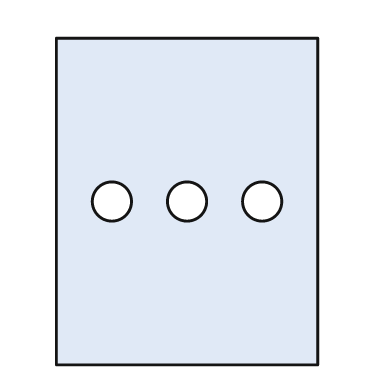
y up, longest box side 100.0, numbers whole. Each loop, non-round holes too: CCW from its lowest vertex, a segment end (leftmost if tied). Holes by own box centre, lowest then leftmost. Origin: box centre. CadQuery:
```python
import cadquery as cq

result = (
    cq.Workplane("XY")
    .moveTo(-40.0, -50.0)
    .lineTo(40.0, -50.0)
    .lineTo(40.0, 50.0)
    .lineTo(-40.0, 50.0)
    .close()
    .moveTo(-23.0, 0.0)
    .circle(6.0)
    .moveTo(0.0, 0.0)
    .circle(6.0)
    .moveTo(23.0, 0.0)
    .circle(6.0)
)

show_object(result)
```